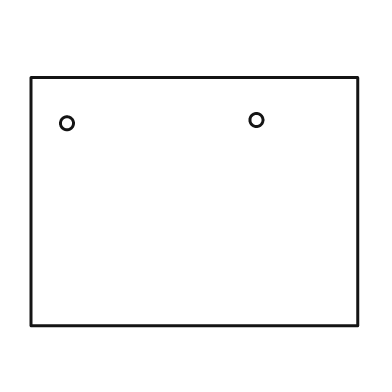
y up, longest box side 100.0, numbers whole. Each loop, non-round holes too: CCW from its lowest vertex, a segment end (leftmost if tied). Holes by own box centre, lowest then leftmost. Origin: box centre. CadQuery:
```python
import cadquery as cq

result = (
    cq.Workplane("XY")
    .moveTo(-50.0, -38.0)
    .lineTo(50.0, -38.0)
    .lineTo(50.0, 38.0)
    .lineTo(-50.0, 38.0)
    .close()
    .moveTo(-39.0, 24.0)
    .circle(2.0)
    .moveTo(19.0, 25.0)
    .circle(2.0)
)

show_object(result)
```